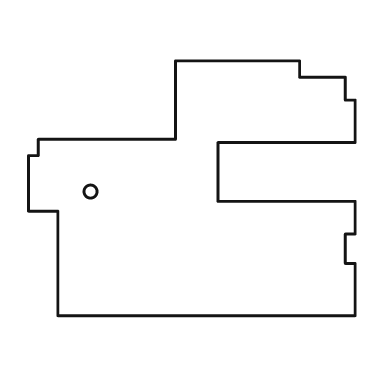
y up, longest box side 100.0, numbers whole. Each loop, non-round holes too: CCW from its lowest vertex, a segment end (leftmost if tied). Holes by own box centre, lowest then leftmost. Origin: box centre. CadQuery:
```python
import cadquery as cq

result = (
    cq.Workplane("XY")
    .moveTo(-41.0, -39.0)
    .lineTo(50.0, -39.0)
    .lineTo(50.0, -23.0)
    .lineTo(47.0, -23.0)
    .lineTo(47.0, -14.0)
    .lineTo(50.0, -14.0)
    .lineTo(50.0, -4.0)
    .lineTo(8.0, -4.0)
    .lineTo(8.0, 14.0)
    .lineTo(50.0, 14.0)
    .lineTo(50.0, 27.0)
    .lineTo(47.0, 27.0)
    .lineTo(47.0, 34.0)
    .lineTo(33.0, 34.0)
    .lineTo(33.0, 39.0)
    .lineTo(-5.0, 39.0)
    .lineTo(-5.0, 15.0)
    .lineTo(-47.0, 15.0)
    .lineTo(-47.0, 10.0)
    .lineTo(-50.0, 10.0)
    .lineTo(-50.0, -7.0)
    .lineTo(-41.0, -7.0)
    .close()
    .moveTo(-31.0, -1.0)
    .circle(2.0)
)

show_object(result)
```